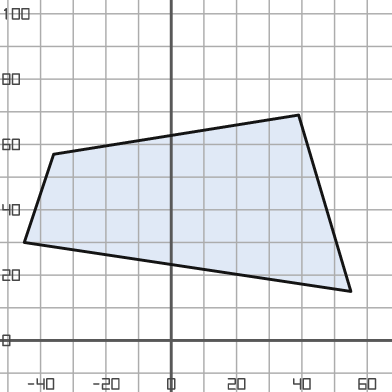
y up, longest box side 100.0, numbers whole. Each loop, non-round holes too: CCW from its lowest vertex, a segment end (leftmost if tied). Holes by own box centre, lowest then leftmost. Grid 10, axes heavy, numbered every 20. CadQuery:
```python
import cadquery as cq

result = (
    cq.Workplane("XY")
    .moveTo(55.0, 15.0)
    .lineTo(39.0, 69.0)
    .lineTo(-36.0, 57.0)
    .lineTo(-45.0, 30.0)
    .close()
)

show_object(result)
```